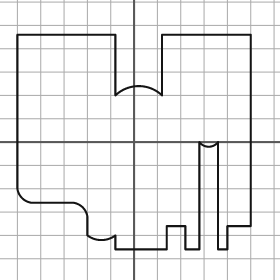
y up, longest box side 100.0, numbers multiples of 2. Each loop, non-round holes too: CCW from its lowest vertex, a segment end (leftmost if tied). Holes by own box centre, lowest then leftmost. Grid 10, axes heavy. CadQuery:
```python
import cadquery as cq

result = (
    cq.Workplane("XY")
    .moveTo(-8.0, -46.0)
    .lineTo(14.0, -46.0)
    .lineTo(14.0, -36.0)
    .lineTo(22.0, -36.0)
    .lineTo(22.0, -46.0)
    .lineTo(28.0, -46.0)
    .lineTo(28.0, 0.0)
    .threePointArc((32.0, -2.0), (36.0, 0.0))
    .lineTo(36.0, -46.0)
    .lineTo(40.0, -46.0)
    .lineTo(40.0, -36.0)
    .lineTo(50.0, -36.0)
    .lineTo(50.0, 46.0)
    .lineTo(12.0, 46.0)
    .lineTo(12.0, 20.0)
    .threePointArc((2.0, 24.0), (-8.0, 20.0))
    .lineTo(-8.0, 46.0)
    .lineTo(-50.0, 46.0)
    .lineTo(-50.0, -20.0)
    .threePointArc((-48.0, -24.0), (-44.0, -26.0))
    .lineTo(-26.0, -26.0)
    .threePointArc((-22.0, -28.0), (-20.0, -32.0))
    .lineTo(-20.0, -40.0)
    .threePointArc((-14.0, -42.0), (-8.0, -40.0))
    .close()
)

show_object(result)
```